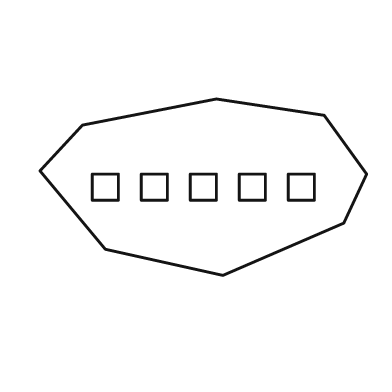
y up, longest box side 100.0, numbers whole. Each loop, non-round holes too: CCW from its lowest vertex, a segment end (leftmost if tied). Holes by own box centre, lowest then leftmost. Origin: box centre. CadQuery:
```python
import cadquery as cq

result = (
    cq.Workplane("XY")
    .moveTo(6.0, -27.0)
    .lineTo(43.0, -11.0)
    .lineTo(50.0, 4.0)
    .lineTo(37.0, 22.0)
    .lineTo(4.0, 27.0)
    .lineTo(-37.0, 19.0)
    .lineTo(-50.0, 5.0)
    .lineTo(-30.0, -19.0)
    .close()
    .moveTo(-34.0, -4.0)
    .lineTo(-26.0, -4.0)
    .lineTo(-26.0, 4.0)
    .lineTo(-34.0, 4.0)
    .close()
    .moveTo(-19.0, -4.0)
    .lineTo(-11.0, -4.0)
    .lineTo(-11.0, 4.0)
    .lineTo(-19.0, 4.0)
    .close()
    .moveTo(-4.0, -4.0)
    .lineTo(4.0, -4.0)
    .lineTo(4.0, 4.0)
    .lineTo(-4.0, 4.0)
    .close()
    .moveTo(11.0, -4.0)
    .lineTo(19.0, -4.0)
    .lineTo(19.0, 4.0)
    .lineTo(11.0, 4.0)
    .close()
    .moveTo(26.0, -4.0)
    .lineTo(34.0, -4.0)
    .lineTo(34.0, 4.0)
    .lineTo(26.0, 4.0)
    .close()
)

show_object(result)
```